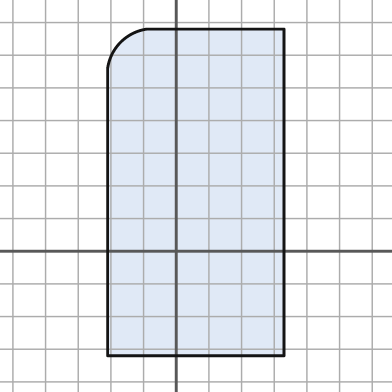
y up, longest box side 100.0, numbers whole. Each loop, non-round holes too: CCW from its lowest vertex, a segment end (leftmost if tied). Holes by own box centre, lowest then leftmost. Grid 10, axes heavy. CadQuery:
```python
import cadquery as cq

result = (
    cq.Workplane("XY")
    .moveTo(-21.0, -32.0)
    .lineTo(33.0, -32.0)
    .lineTo(33.0, 68.0)
    .lineTo(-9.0, 68.0)
    .threePointArc((-17.0, 64.0), (-21.0, 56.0))
    .close()
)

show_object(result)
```